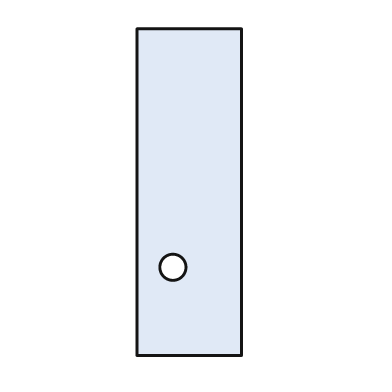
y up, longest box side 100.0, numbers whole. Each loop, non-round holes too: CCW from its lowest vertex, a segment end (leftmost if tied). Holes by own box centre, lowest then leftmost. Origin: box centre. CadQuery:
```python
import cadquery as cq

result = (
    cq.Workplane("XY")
    .moveTo(-16.0, -50.0)
    .lineTo(16.0, -50.0)
    .lineTo(16.0, 50.0)
    .lineTo(-16.0, 50.0)
    .close()
    .moveTo(-5.0, -23.0)
    .circle(4.0)
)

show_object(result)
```